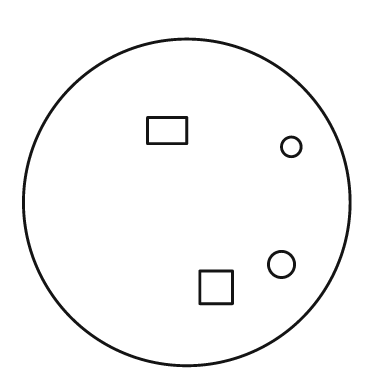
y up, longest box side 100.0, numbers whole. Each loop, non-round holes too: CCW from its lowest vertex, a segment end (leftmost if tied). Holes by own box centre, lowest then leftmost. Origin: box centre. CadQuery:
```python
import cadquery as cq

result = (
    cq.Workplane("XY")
    .moveTo(0.0, 0.0)
    .circle(50.0)
    .moveTo(4.0, -31.0)
    .lineTo(14.0, -31.0)
    .lineTo(14.0, -21.0)
    .lineTo(4.0, -21.0)
    .close()
    .moveTo(29.0, -19.0)
    .circle(4.0)
    .moveTo(32.0, 17.0)
    .circle(3.0)
    .moveTo(-12.0, 18.0)
    .lineTo(0.0, 18.0)
    .lineTo(0.0, 26.0)
    .lineTo(-12.0, 26.0)
    .close()
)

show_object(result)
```